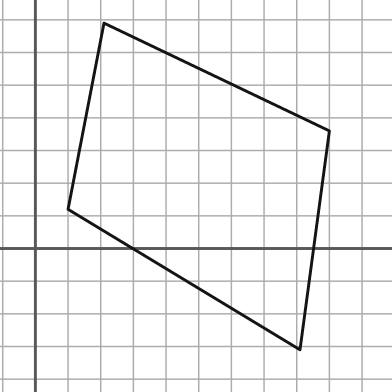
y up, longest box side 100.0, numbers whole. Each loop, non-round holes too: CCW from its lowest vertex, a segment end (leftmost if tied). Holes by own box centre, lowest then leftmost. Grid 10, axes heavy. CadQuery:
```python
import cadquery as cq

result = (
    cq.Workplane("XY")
    .moveTo(81.0, -31.0)
    .lineTo(90.0, 36.0)
    .lineTo(21.0, 69.0)
    .lineTo(10.0, 12.0)
    .close()
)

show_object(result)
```